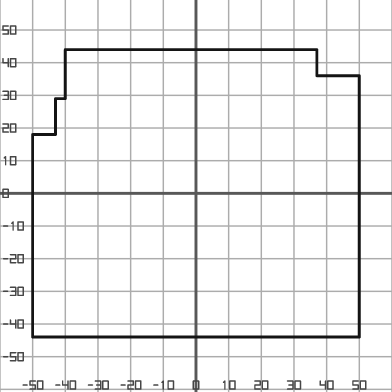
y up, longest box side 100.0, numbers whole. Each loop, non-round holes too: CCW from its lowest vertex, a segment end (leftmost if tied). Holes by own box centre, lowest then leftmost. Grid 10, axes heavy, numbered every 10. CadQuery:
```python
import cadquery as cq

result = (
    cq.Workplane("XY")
    .moveTo(-50.0, -44.0)
    .lineTo(50.0, -44.0)
    .lineTo(50.0, 36.0)
    .lineTo(37.0, 36.0)
    .lineTo(37.0, 44.0)
    .lineTo(-40.0, 44.0)
    .lineTo(-40.0, 29.0)
    .lineTo(-43.0, 29.0)
    .lineTo(-43.0, 18.0)
    .lineTo(-50.0, 18.0)
    .close()
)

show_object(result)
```